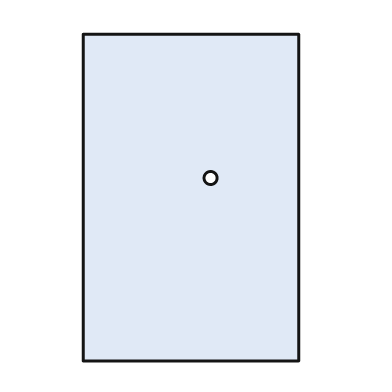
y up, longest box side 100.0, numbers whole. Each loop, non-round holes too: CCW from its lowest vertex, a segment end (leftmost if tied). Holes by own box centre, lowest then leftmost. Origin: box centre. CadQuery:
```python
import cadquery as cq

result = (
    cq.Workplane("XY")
    .moveTo(-33.0, -50.0)
    .lineTo(33.0, -50.0)
    .lineTo(33.0, 50.0)
    .lineTo(-33.0, 50.0)
    .close()
    .moveTo(6.0, 6.0)
    .circle(2.0)
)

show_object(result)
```